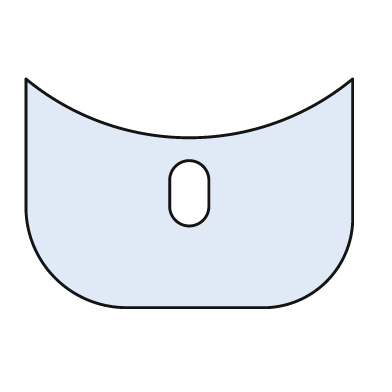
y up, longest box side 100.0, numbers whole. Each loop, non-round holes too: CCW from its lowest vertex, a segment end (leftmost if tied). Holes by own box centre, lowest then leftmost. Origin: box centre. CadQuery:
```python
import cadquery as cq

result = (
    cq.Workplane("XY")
    .moveTo(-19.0, -35.0)
    .lineTo(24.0, -35.0)
    .threePointArc((42.0, -27.0), (50.0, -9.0))
    .lineTo(50.0, 35.0)
    .threePointArc((0.0, 17.0), (-50.0, 35.0))
    .lineTo(-50.0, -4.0)
    .threePointArc((-41.0, -26.0), (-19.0, -35.0))
    .close()
    .moveTo(-6.0, -4.0)
    .threePointArc((0.0, -10.0), (6.0, -4.0))
    .lineTo(6.0, 4.0)
    .threePointArc((0.0, 10.0), (-6.0, 4.0))
    .close()
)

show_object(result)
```